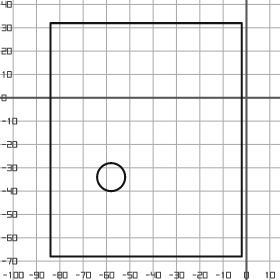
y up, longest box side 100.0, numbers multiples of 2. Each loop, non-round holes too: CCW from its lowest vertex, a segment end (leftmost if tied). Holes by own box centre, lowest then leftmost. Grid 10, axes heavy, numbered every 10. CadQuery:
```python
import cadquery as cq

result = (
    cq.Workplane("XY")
    .moveTo(-84.0, -68.0)
    .lineTo(-2.0, -68.0)
    .lineTo(-2.0, 32.0)
    .lineTo(-84.0, 32.0)
    .close()
    .moveTo(-58.0, -34.0)
    .circle(6.0)
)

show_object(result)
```